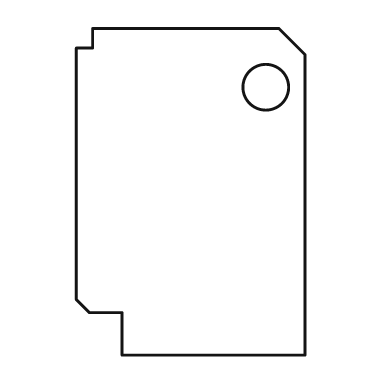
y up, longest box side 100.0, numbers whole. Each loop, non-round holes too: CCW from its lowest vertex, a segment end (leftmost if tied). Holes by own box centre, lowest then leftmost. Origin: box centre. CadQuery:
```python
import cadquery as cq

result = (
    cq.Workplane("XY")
    .moveTo(-21.0, -50.0)
    .lineTo(35.0, -50.0)
    .lineTo(35.0, 42.0)
    .lineTo(27.0, 50.0)
    .lineTo(-30.0, 50.0)
    .lineTo(-30.0, 44.0)
    .lineTo(-35.0, 44.0)
    .lineTo(-35.0, -33.0)
    .lineTo(-31.0, -37.0)
    .lineTo(-21.0, -37.0)
    .close()
    .moveTo(23.0, 32.0)
    .circle(7.0)
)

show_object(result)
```